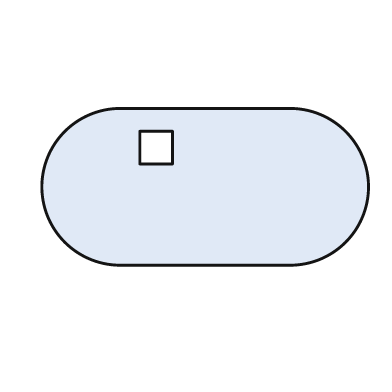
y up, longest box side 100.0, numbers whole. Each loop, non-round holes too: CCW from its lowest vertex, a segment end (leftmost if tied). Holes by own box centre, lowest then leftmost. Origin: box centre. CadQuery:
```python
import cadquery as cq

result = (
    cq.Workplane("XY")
    .moveTo(-26.0, -24.0)
    .lineTo(26.0, -24.0)
    .threePointArc((50.0, 0.0), (26.0, 24.0))
    .lineTo(-26.0, 24.0)
    .threePointArc((-50.0, 0.0), (-26.0, -24.0))
    .close()
    .moveTo(-20.0, 7.0)
    .lineTo(-10.0, 7.0)
    .lineTo(-10.0, 17.0)
    .lineTo(-20.0, 17.0)
    .close()
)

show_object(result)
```